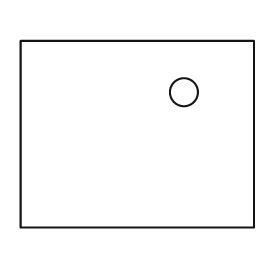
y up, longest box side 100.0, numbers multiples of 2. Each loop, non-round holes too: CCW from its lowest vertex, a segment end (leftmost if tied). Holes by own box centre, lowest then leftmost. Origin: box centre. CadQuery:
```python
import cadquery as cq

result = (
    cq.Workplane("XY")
    .moveTo(-50.0, -40.0)
    .lineTo(50.0, -40.0)
    .lineTo(50.0, 40.0)
    .lineTo(-50.0, 40.0)
    .close()
    .moveTo(20.0, 18.0)
    .circle(6.0)
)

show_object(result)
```